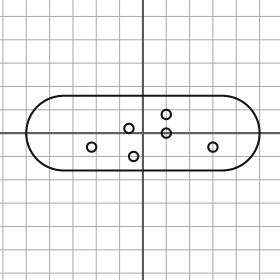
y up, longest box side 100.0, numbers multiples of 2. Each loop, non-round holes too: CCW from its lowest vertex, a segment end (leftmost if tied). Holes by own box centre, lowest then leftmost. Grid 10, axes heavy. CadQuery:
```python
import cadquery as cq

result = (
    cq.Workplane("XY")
    .moveTo(-34.0, -16.0)
    .lineTo(34.0, -16.0)
    .threePointArc((50.0, 0.0), (34.0, 16.0))
    .lineTo(-34.0, 16.0)
    .threePointArc((-50.0, 0.0), (-34.0, -16.0))
    .close()
    .moveTo(-4.0, -10.0)
    .circle(2.0)
    .moveTo(-22.0, -6.0)
    .circle(2.0)
    .moveTo(30.0, -6.0)
    .circle(2.0)
    .moveTo(10.0, 0.0)
    .circle(2.0)
    .moveTo(-6.0, 2.0)
    .circle(2.0)
    .moveTo(10.0, 8.0)
    .circle(2.0)
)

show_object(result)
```